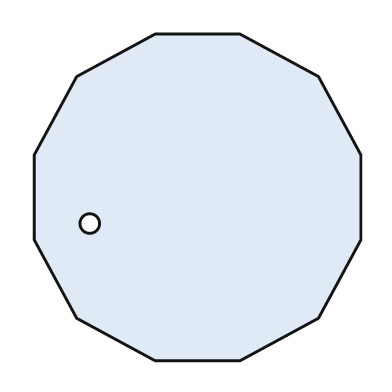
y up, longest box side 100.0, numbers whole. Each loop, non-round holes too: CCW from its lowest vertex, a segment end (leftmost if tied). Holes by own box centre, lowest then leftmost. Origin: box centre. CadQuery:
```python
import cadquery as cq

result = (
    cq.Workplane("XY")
    .moveTo(-13.0, -50.0)
    .lineTo(13.0, -50.0)
    .lineTo(37.0, -37.0)
    .lineTo(50.0, -13.0)
    .lineTo(50.0, 13.0)
    .lineTo(37.0, 37.0)
    .lineTo(13.0, 50.0)
    .lineTo(-13.0, 50.0)
    .lineTo(-37.0, 37.0)
    .lineTo(-50.0, 13.0)
    .lineTo(-50.0, -13.0)
    .lineTo(-37.0, -37.0)
    .close()
    .moveTo(-33.0, -8.0)
    .circle(3.0)
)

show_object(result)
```